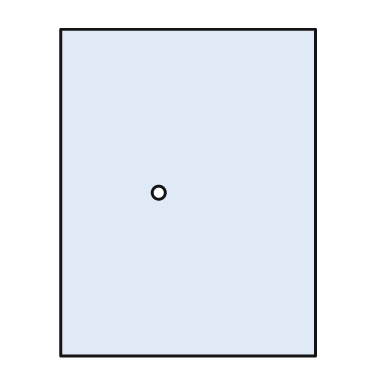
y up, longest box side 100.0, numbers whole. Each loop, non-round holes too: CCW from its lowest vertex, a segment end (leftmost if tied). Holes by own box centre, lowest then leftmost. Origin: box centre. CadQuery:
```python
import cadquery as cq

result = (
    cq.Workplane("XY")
    .moveTo(-39.0, -50.0)
    .lineTo(39.0, -50.0)
    .lineTo(39.0, 50.0)
    .lineTo(-39.0, 50.0)
    .close()
    .moveTo(-9.0, 0.0)
    .circle(2.0)
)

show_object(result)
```